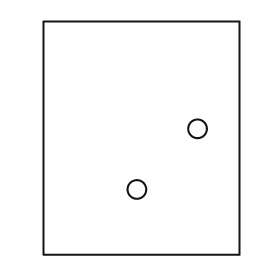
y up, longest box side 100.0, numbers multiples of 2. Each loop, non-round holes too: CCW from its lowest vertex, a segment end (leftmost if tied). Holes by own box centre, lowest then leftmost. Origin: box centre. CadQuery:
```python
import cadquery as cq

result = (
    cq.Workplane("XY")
    .moveTo(-42.0, -50.0)
    .lineTo(42.0, -50.0)
    .lineTo(42.0, 50.0)
    .lineTo(-42.0, 50.0)
    .close()
    .moveTo(-2.0, -22.0)
    .circle(4.0)
    .moveTo(24.0, 4.0)
    .circle(4.0)
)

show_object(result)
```